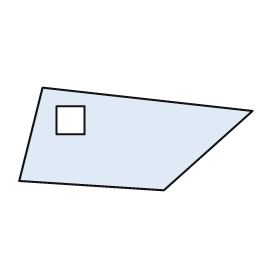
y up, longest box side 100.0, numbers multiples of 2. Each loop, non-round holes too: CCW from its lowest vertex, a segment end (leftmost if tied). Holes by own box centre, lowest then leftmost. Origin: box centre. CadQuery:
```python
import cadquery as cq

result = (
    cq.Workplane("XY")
    .moveTo(12.0, -22.0)
    .lineTo(50.0, 12.0)
    .lineTo(-40.0, 22.0)
    .lineTo(-50.0, -18.0)
    .close()
    .moveTo(-34.0, 2.0)
    .lineTo(-22.0, 2.0)
    .lineTo(-22.0, 14.0)
    .lineTo(-34.0, 14.0)
    .close()
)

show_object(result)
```